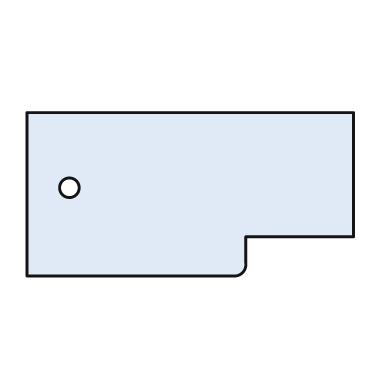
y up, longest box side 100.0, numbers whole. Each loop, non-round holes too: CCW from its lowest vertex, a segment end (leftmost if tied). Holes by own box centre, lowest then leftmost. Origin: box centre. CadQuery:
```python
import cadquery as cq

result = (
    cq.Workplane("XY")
    .moveTo(-50.0, -25.0)
    .lineTo(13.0, -25.0)
    .threePointArc((16.0, -24.0), (17.0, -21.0))
    .lineTo(17.0, -13.0)
    .lineTo(50.0, -13.0)
    .lineTo(50.0, 25.0)
    .lineTo(-50.0, 25.0)
    .close()
    .moveTo(-37.0, 2.0)
    .circle(3.0)
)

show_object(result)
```